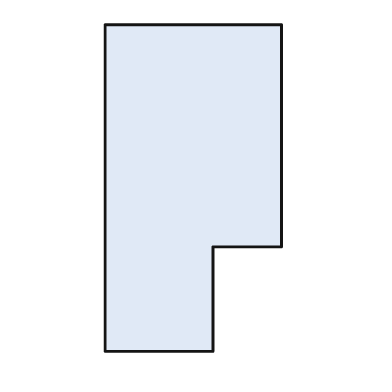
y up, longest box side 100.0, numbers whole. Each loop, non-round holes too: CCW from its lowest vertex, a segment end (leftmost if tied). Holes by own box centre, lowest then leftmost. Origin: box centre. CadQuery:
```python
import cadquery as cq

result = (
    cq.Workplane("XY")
    .moveTo(-27.0, -50.0)
    .lineTo(6.0, -50.0)
    .lineTo(6.0, -18.0)
    .lineTo(27.0, -18.0)
    .lineTo(27.0, 50.0)
    .lineTo(-27.0, 50.0)
    .close()
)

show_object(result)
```